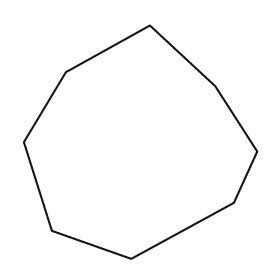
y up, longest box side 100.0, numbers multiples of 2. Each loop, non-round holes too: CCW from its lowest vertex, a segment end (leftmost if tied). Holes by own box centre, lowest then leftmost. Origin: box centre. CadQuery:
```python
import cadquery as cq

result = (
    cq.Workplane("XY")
    .moveTo(-4.0, -50.0)
    .lineTo(40.0, -26.0)
    .lineTo(50.0, -4.0)
    .lineTo(32.0, 24.0)
    .lineTo(4.0, 50.0)
    .lineTo(-32.0, 30.0)
    .lineTo(-50.0, 0.0)
    .lineTo(-38.0, -38.0)
    .close()
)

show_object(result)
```